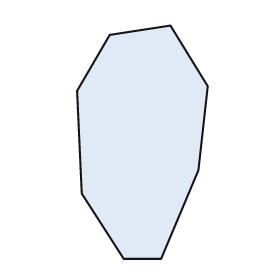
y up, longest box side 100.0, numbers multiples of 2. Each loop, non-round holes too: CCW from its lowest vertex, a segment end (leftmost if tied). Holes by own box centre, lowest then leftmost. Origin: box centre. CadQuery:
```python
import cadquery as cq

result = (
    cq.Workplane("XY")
    .moveTo(-8.0, -50.0)
    .lineTo(8.0, -50.0)
    .lineTo(24.0, -12.0)
    .lineTo(28.0, 24.0)
    .lineTo(12.0, 50.0)
    .lineTo(-14.0, 46.0)
    .lineTo(-28.0, 22.0)
    .lineTo(-26.0, -22.0)
    .close()
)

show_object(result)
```